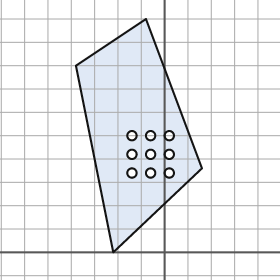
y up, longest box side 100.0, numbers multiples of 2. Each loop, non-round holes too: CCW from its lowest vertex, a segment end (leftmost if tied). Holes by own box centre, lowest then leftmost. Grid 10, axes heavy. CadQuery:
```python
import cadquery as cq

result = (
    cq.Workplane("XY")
    .moveTo(-22.0, 0.0)
    .lineTo(16.0, 36.0)
    .lineTo(-8.0, 100.0)
    .lineTo(-38.0, 80.0)
    .close()
    .moveTo(-14.0, 34.0)
    .circle(2.0)
    .moveTo(-6.0, 34.0)
    .circle(2.0)
    .moveTo(2.0, 34.0)
    .circle(2.0)
    .moveTo(-14.0, 42.0)
    .circle(2.0)
    .moveTo(-6.0, 42.0)
    .circle(2.0)
    .moveTo(2.0, 42.0)
    .circle(2.0)
    .moveTo(-14.0, 50.0)
    .circle(2.0)
    .moveTo(-6.0, 50.0)
    .circle(2.0)
    .moveTo(2.0, 50.0)
    .circle(2.0)
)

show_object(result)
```